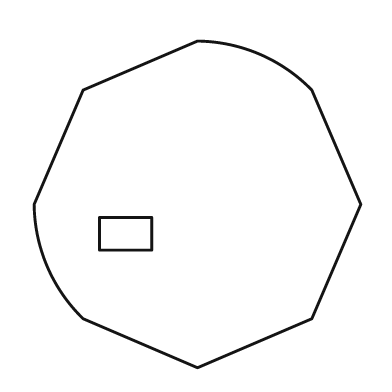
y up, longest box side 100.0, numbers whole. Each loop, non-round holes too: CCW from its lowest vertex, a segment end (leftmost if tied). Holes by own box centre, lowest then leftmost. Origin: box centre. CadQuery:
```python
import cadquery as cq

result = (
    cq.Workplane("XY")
    .moveTo(0.0, -50.0)
    .lineTo(35.0, -35.0)
    .lineTo(50.0, 0.0)
    .lineTo(35.0, 35.0)
    .threePointArc((19.0, 46.0), (0.0, 50.0))
    .lineTo(-35.0, 35.0)
    .lineTo(-50.0, 0.0)
    .threePointArc((-46.0, -19.0), (-35.0, -35.0))
    .close()
    .moveTo(-30.0, -14.0)
    .lineTo(-14.0, -14.0)
    .lineTo(-14.0, -4.0)
    .lineTo(-30.0, -4.0)
    .close()
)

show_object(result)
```